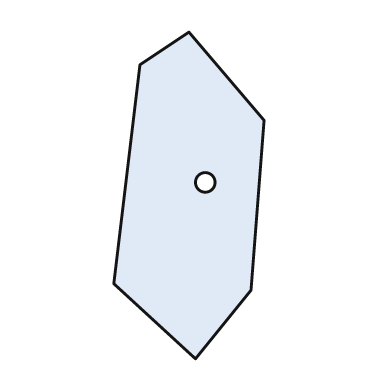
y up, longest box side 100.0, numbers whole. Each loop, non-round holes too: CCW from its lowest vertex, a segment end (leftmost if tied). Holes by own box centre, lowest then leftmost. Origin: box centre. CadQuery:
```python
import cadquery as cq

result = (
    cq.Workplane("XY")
    .moveTo(2.0, -50.0)
    .lineTo(19.0, -29.0)
    .lineTo(23.0, 23.0)
    .lineTo(0.0, 50.0)
    .lineTo(-15.0, 40.0)
    .lineTo(-23.0, -27.0)
    .close()
    .moveTo(5.0, 4.0)
    .circle(3.0)
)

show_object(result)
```